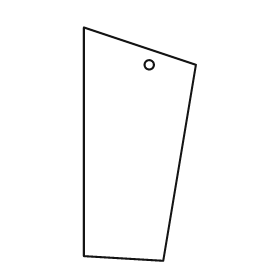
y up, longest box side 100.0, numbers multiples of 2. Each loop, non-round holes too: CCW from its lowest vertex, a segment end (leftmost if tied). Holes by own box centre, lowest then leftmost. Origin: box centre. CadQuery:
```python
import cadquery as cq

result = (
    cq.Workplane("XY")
    .moveTo(10.0, -50.0)
    .lineTo(24.0, 34.0)
    .lineTo(-24.0, 50.0)
    .lineTo(-24.0, -48.0)
    .close()
    .moveTo(4.0, 34.0)
    .circle(2.0)
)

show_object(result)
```